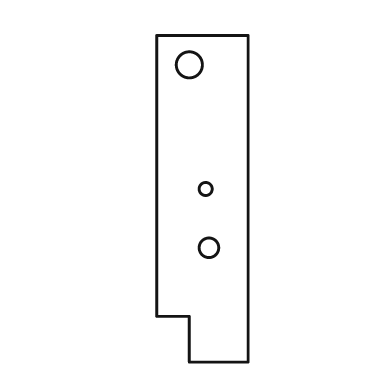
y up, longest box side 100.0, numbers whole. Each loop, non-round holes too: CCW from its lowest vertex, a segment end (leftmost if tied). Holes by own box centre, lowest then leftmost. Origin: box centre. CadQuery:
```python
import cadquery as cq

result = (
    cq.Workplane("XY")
    .moveTo(-4.0, -50.0)
    .lineTo(14.0, -50.0)
    .lineTo(14.0, 50.0)
    .lineTo(-14.0, 50.0)
    .lineTo(-14.0, -36.0)
    .lineTo(-4.0, -36.0)
    .close()
    .moveTo(2.0, -15.0)
    .circle(3.0)
    .moveTo(1.0, 3.0)
    .circle(2.0)
    .moveTo(-4.0, 41.0)
    .circle(4.0)
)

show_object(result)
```